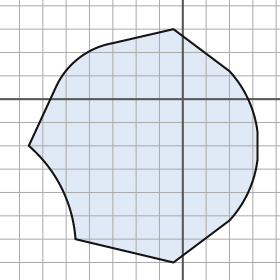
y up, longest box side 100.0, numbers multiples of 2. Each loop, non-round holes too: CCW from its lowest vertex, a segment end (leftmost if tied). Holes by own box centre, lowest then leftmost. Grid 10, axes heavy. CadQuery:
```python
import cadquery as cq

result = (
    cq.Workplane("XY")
    .moveTo(-4.0, -70.0)
    .lineTo(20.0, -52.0)
    .threePointArc((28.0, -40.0), (32.0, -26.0))
    .lineTo(32.0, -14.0)
    .threePointArc((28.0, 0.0), (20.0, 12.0))
    .lineTo(-4.0, 30.0)
    .lineTo(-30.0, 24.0)
    .threePointArc((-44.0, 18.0), (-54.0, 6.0))
    .lineTo(-66.0, -20.0)
    .threePointArc((-52.0, -38.0), (-46.0, -60.0))
    .close()
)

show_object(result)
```